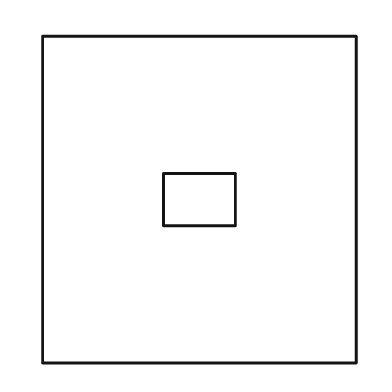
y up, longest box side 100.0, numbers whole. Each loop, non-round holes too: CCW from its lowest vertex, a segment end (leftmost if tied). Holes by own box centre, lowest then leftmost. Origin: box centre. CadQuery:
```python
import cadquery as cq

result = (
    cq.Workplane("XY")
    .moveTo(-48.0, -50.0)
    .lineTo(48.0, -50.0)
    .lineTo(48.0, 50.0)
    .lineTo(-48.0, 50.0)
    .close()
    .moveTo(-11.0, -8.0)
    .lineTo(11.0, -8.0)
    .lineTo(11.0, 8.0)
    .lineTo(-11.0, 8.0)
    .close()
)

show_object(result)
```